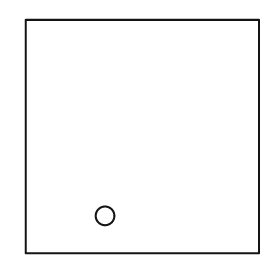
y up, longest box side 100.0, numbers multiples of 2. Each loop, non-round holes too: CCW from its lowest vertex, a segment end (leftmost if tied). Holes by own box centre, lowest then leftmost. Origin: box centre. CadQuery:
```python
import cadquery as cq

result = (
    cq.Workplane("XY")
    .moveTo(-50.0, -50.0)
    .lineTo(50.0, -50.0)
    .lineTo(50.0, 50.0)
    .lineTo(-50.0, 50.0)
    .close()
    .moveTo(-16.0, -34.0)
    .circle(4.0)
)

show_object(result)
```